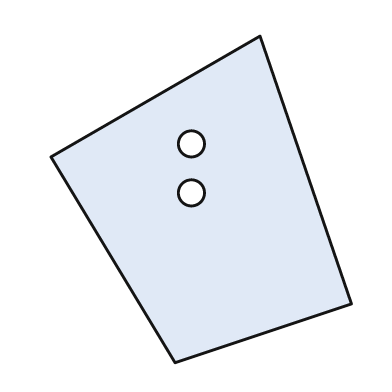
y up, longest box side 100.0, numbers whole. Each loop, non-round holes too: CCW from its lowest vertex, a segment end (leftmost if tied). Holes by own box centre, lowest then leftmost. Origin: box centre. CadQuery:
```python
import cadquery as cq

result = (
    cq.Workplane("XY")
    .moveTo(-8.0, -50.0)
    .lineTo(46.0, -32.0)
    .lineTo(18.0, 50.0)
    .lineTo(-46.0, 13.0)
    .close()
    .moveTo(-3.0, 2.0)
    .circle(4.0)
    .moveTo(-3.0, 17.0)
    .circle(4.0)
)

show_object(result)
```